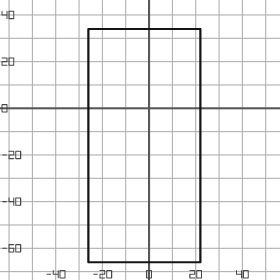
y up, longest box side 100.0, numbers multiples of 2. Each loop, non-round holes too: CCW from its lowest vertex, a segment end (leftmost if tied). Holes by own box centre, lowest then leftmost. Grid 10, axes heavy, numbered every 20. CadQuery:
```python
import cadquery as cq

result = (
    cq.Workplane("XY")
    .moveTo(-26.0, -66.0)
    .lineTo(22.0, -66.0)
    .lineTo(22.0, 34.0)
    .lineTo(-26.0, 34.0)
    .close()
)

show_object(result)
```